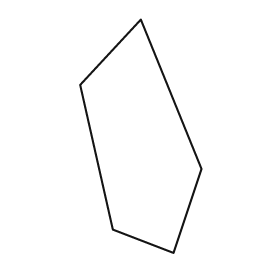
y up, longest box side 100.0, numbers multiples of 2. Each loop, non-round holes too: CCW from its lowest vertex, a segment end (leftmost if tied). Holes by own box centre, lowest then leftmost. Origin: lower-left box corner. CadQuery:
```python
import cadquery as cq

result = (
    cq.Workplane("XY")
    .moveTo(40.0, 0.0)
    .lineTo(52.0, 36.0)
    .lineTo(26.0, 100.0)
    .lineTo(0.0, 72.0)
    .lineTo(14.0, 10.0)
    .close()
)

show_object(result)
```